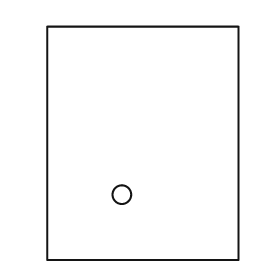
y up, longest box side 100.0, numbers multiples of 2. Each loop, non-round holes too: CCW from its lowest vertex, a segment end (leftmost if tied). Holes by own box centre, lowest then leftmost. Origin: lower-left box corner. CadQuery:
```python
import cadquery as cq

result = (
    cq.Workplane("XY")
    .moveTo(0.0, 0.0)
    .lineTo(82.0, 0.0)
    .lineTo(82.0, 100.0)
    .lineTo(0.0, 100.0)
    .close()
    .moveTo(32.0, 28.0)
    .circle(4.0)
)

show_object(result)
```